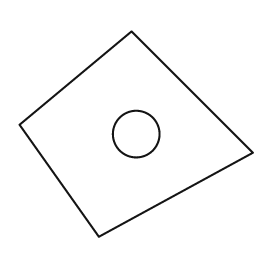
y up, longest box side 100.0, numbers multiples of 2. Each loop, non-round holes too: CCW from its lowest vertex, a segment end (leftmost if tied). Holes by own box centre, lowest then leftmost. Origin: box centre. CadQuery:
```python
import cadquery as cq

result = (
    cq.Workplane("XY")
    .moveTo(-16.0, -44.0)
    .lineTo(50.0, -8.0)
    .lineTo(-2.0, 44.0)
    .lineTo(-50.0, 4.0)
    .close()
    .moveTo(0.0, 0.0)
    .circle(10.0)
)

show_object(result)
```